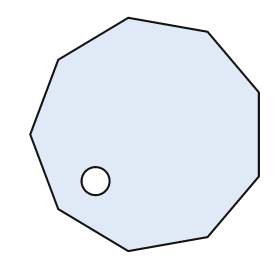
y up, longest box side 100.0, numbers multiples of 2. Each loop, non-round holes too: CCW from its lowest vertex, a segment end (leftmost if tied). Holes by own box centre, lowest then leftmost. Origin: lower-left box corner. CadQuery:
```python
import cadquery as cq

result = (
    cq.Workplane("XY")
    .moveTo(42.0, 0.0)
    .lineTo(76.0, 6.0)
    .lineTo(98.0, 32.0)
    .lineTo(98.0, 68.0)
    .lineTo(76.0, 94.0)
    .lineTo(42.0, 100.0)
    .lineTo(12.0, 82.0)
    .lineTo(0.0, 50.0)
    .lineTo(12.0, 18.0)
    .close()
    .moveTo(28.0, 30.0)
    .circle(6.0)
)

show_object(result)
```